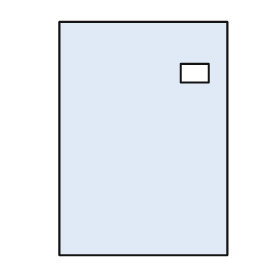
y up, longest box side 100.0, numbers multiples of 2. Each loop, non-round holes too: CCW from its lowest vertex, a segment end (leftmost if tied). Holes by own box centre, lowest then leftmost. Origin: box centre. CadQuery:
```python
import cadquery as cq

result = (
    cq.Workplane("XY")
    .moveTo(-36.0, -50.0)
    .lineTo(36.0, -50.0)
    .lineTo(36.0, 50.0)
    .lineTo(-36.0, 50.0)
    .close()
    .moveTo(16.0, 24.0)
    .lineTo(28.0, 24.0)
    .lineTo(28.0, 32.0)
    .lineTo(16.0, 32.0)
    .close()
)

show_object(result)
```